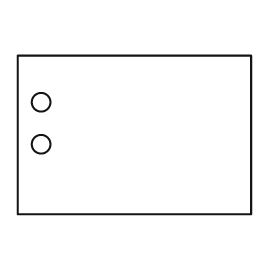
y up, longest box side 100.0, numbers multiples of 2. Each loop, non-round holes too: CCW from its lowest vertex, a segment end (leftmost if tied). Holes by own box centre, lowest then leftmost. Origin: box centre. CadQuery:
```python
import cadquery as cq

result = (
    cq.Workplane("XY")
    .moveTo(-50.0, -34.0)
    .lineTo(50.0, -34.0)
    .lineTo(50.0, 34.0)
    .lineTo(-50.0, 34.0)
    .close()
    .moveTo(-40.0, -4.0)
    .circle(4.0)
    .moveTo(-40.0, 14.0)
    .circle(4.0)
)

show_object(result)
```